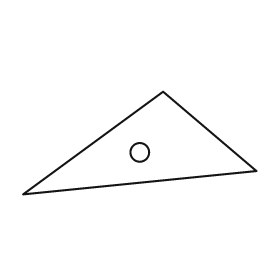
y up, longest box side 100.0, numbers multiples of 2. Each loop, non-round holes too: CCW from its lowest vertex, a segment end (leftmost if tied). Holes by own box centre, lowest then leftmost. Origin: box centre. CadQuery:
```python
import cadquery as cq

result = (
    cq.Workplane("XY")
    .moveTo(-50.0, -22.0)
    .lineTo(50.0, -12.0)
    .lineTo(10.0, 22.0)
    .close()
    .moveTo(0.0, -4.0)
    .circle(4.0)
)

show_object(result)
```